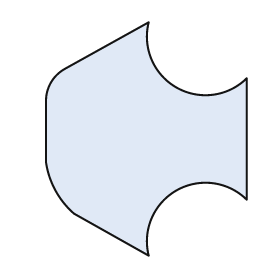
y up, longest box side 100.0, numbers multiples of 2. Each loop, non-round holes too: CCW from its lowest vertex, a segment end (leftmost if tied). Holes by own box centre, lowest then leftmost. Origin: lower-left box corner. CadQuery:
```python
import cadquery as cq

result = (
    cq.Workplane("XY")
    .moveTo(44.0, 0.0)
    .threePointArc((56.0, 28.0), (86.0, 24.0))
    .lineTo(86.0, 76.0)
    .threePointArc((56.0, 72.0), (44.0, 100.0))
    .lineTo(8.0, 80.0)
    .threePointArc((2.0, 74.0), (0.0, 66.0))
    .lineTo(0.0, 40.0)
    .threePointArc((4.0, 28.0), (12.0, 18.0))
    .close()
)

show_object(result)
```